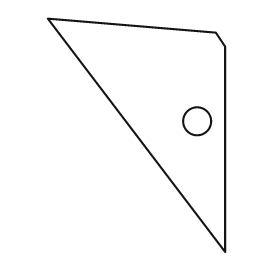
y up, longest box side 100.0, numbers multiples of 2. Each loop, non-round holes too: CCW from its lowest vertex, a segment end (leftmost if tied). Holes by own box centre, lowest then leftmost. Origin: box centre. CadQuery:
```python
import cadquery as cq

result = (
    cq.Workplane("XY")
    .moveTo(38.0, -50.0)
    .lineTo(38.0, 38.0)
    .lineTo(34.0, 44.0)
    .lineTo(-38.0, 50.0)
    .close()
    .moveTo(26.0, 6.0)
    .circle(6.0)
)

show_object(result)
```